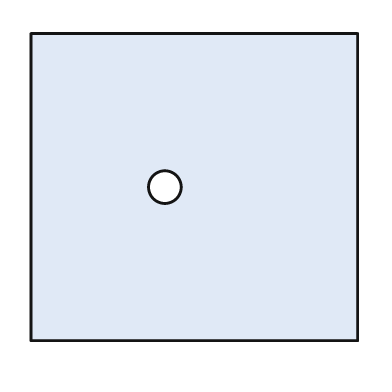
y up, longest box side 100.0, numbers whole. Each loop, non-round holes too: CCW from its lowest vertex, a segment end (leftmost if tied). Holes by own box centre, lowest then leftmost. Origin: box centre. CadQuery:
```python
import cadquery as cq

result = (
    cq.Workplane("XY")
    .moveTo(-50.0, -47.0)
    .lineTo(50.0, -47.0)
    .lineTo(50.0, 47.0)
    .lineTo(-50.0, 47.0)
    .close()
    .moveTo(-9.0, 0.0)
    .circle(5.0)
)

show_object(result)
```